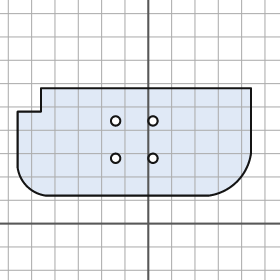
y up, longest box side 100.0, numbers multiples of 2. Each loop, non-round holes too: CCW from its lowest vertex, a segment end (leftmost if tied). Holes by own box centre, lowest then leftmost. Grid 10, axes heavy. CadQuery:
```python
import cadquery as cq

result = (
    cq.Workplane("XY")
    .moveTo(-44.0, 12.0)
    .lineTo(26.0, 12.0)
    .threePointArc((38.0, 18.0), (44.0, 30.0))
    .lineTo(44.0, 58.0)
    .lineTo(-46.0, 58.0)
    .lineTo(-46.0, 48.0)
    .lineTo(-56.0, 48.0)
    .lineTo(-56.0, 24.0)
    .threePointArc((-52.0, 16.0), (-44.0, 12.0))
    .close()
    .moveTo(-14.0, 28.0)
    .circle(2.0)
    .moveTo(2.0, 28.0)
    .circle(2.0)
    .moveTo(-14.0, 44.0)
    .circle(2.0)
    .moveTo(2.0, 44.0)
    .circle(2.0)
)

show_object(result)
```